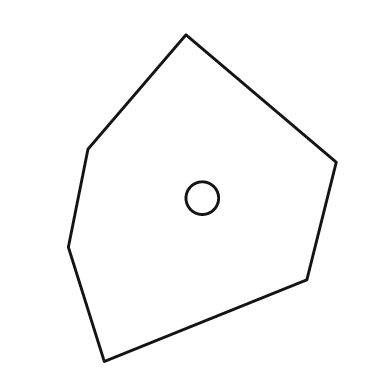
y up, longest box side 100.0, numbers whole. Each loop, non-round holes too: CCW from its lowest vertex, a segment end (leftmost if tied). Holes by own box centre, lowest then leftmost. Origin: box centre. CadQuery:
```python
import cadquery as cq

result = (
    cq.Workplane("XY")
    .moveTo(-30.0, -50.0)
    .lineTo(32.0, -25.0)
    .lineTo(41.0, 11.0)
    .lineTo(-5.0, 50.0)
    .lineTo(-35.0, 15.0)
    .lineTo(-41.0, -15.0)
    .close()
    .moveTo(0.0, 0.0)
    .circle(5.0)
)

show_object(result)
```